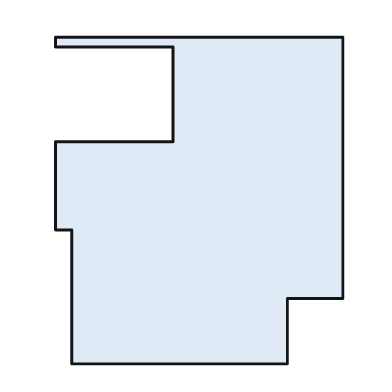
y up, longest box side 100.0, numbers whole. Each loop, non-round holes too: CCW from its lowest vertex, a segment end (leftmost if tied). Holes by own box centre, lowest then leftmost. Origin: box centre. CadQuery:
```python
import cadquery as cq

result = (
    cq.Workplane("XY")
    .moveTo(-39.0, -50.0)
    .lineTo(27.0, -50.0)
    .lineTo(27.0, -30.0)
    .lineTo(44.0, -30.0)
    .lineTo(44.0, 50.0)
    .lineTo(-44.0, 50.0)
    .lineTo(-44.0, 47.0)
    .lineTo(-8.0, 47.0)
    .lineTo(-8.0, 18.0)
    .lineTo(-44.0, 18.0)
    .lineTo(-44.0, -9.0)
    .lineTo(-39.0, -9.0)
    .close()
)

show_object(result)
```